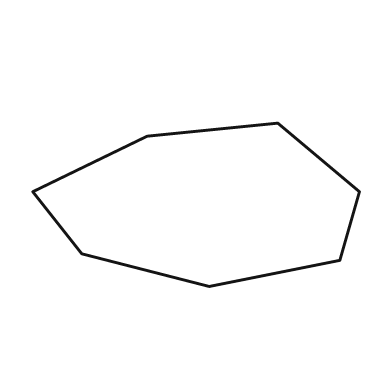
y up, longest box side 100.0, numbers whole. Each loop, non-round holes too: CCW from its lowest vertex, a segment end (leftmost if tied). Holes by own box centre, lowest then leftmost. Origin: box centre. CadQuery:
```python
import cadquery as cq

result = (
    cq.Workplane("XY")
    .moveTo(4.0, -25.0)
    .lineTo(44.0, -17.0)
    .lineTo(50.0, 4.0)
    .lineTo(25.0, 25.0)
    .lineTo(-15.0, 21.0)
    .lineTo(-50.0, 4.0)
    .lineTo(-35.0, -15.0)
    .close()
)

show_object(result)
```